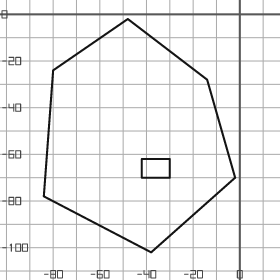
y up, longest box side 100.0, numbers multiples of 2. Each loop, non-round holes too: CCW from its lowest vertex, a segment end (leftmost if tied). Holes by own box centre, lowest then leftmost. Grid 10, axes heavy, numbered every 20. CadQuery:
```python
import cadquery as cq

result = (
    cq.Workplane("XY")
    .moveTo(-38.0, -102.0)
    .lineTo(-2.0, -70.0)
    .lineTo(-14.0, -28.0)
    .lineTo(-48.0, -2.0)
    .lineTo(-80.0, -24.0)
    .lineTo(-84.0, -78.0)
    .close()
    .moveTo(-42.0, -70.0)
    .lineTo(-30.0, -70.0)
    .lineTo(-30.0, -62.0)
    .lineTo(-42.0, -62.0)
    .close()
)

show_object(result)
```